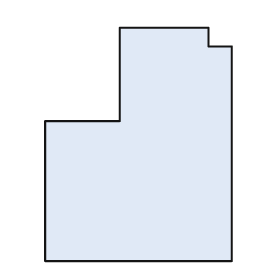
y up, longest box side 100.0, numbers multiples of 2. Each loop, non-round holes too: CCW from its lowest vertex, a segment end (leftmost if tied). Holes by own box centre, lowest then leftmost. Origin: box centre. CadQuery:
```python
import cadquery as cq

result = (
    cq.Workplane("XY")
    .moveTo(-40.0, -50.0)
    .lineTo(40.0, -50.0)
    .lineTo(40.0, 42.0)
    .lineTo(30.0, 42.0)
    .lineTo(30.0, 50.0)
    .lineTo(-8.0, 50.0)
    .lineTo(-8.0, 10.0)
    .lineTo(-40.0, 10.0)
    .close()
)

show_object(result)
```